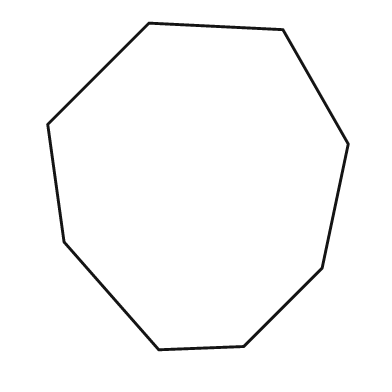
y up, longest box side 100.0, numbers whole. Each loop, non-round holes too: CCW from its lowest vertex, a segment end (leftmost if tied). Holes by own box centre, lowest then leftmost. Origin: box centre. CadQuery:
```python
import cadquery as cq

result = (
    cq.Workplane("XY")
    .moveTo(-12.0, -50.0)
    .lineTo(14.0, -49.0)
    .lineTo(38.0, -25.0)
    .lineTo(46.0, 13.0)
    .lineTo(26.0, 48.0)
    .lineTo(-15.0, 50.0)
    .lineTo(-46.0, 19.0)
    .lineTo(-41.0, -17.0)
    .close()
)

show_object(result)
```